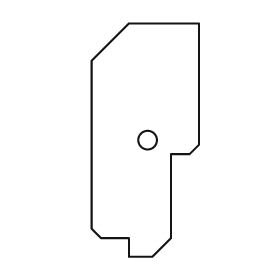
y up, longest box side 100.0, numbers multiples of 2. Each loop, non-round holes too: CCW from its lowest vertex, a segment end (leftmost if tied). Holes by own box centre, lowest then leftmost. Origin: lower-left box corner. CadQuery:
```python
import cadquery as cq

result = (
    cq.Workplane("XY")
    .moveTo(16.0, 0.0)
    .lineTo(26.0, 0.0)
    .lineTo(34.0, 8.0)
    .lineTo(34.0, 44.0)
    .lineTo(42.0, 44.0)
    .lineTo(46.0, 48.0)
    .lineTo(46.0, 100.0)
    .lineTo(16.0, 100.0)
    .lineTo(0.0, 84.0)
    .lineTo(0.0, 12.0)
    .lineTo(4.0, 8.0)
    .lineTo(16.0, 8.0)
    .close()
    .moveTo(24.0, 50.0)
    .circle(4.0)
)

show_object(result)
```